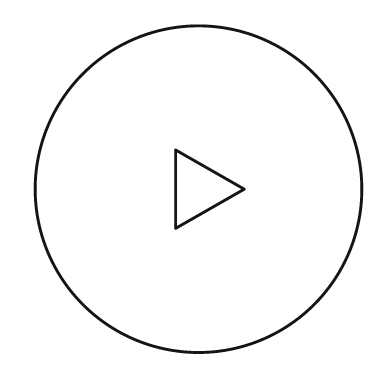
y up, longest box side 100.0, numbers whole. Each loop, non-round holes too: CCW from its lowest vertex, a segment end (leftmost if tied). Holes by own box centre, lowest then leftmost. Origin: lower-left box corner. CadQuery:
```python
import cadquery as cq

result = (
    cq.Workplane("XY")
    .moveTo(50.0, 50.0)
    .circle(50.0)
    .moveTo(43.0, 38.0)
    .lineTo(64.0, 50.0)
    .lineTo(43.0, 62.0)
    .close()
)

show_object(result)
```